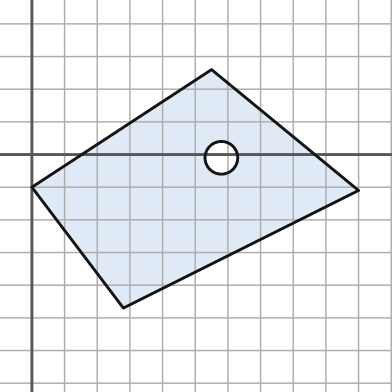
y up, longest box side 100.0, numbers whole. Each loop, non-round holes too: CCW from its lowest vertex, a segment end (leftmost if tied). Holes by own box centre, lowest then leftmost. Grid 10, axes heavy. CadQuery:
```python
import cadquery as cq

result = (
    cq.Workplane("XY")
    .moveTo(28.0, -47.0)
    .lineTo(100.0, -11.0)
    .lineTo(55.0, 26.0)
    .lineTo(0.0, -10.0)
    .close()
    .moveTo(58.0, -1.0)
    .circle(5.0)
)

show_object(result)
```